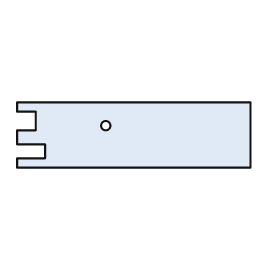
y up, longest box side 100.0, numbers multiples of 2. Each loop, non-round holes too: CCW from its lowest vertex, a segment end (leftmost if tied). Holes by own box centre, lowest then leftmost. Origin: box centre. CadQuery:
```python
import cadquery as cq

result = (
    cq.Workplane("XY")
    .moveTo(-50.0, -14.0)
    .lineTo(50.0, -14.0)
    .lineTo(50.0, 14.0)
    .lineTo(-50.0, 14.0)
    .lineTo(-50.0, 10.0)
    .lineTo(-42.0, 10.0)
    .lineTo(-42.0, 2.0)
    .lineTo(-50.0, 2.0)
    .lineTo(-50.0, -4.0)
    .lineTo(-38.0, -4.0)
    .lineTo(-38.0, -10.0)
    .lineTo(-50.0, -10.0)
    .close()
    .moveTo(-12.0, 4.0)
    .circle(2.0)
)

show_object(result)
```